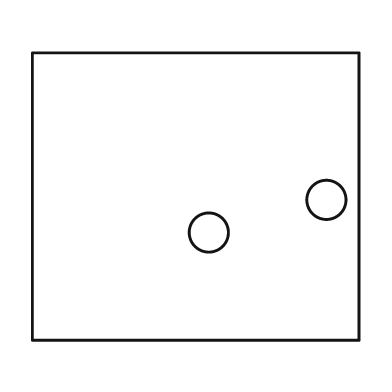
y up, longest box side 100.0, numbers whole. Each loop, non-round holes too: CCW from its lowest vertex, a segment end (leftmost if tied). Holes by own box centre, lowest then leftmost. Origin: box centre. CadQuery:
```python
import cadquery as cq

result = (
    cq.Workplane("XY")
    .moveTo(-50.0, -44.0)
    .lineTo(50.0, -44.0)
    .lineTo(50.0, 44.0)
    .lineTo(-50.0, 44.0)
    .close()
    .moveTo(4.0, -11.0)
    .circle(6.0)
    .moveTo(40.0, -1.0)
    .circle(6.0)
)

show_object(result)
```